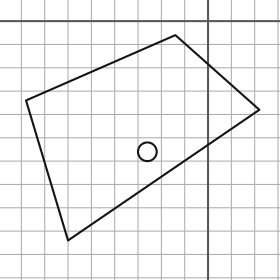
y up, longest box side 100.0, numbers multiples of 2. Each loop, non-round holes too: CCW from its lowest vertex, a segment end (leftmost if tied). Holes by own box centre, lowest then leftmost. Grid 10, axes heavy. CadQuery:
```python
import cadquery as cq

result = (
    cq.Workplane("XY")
    .moveTo(-60.0, -94.0)
    .lineTo(22.0, -38.0)
    .lineTo(-14.0, -6.0)
    .lineTo(-78.0, -34.0)
    .close()
    .moveTo(-26.0, -56.0)
    .circle(4.0)
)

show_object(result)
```